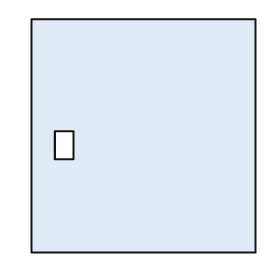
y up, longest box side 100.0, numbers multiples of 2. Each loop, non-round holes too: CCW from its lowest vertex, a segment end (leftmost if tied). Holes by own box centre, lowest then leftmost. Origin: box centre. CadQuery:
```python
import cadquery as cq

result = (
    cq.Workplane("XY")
    .moveTo(-48.0, -50.0)
    .lineTo(48.0, -50.0)
    .lineTo(48.0, 50.0)
    .lineTo(-48.0, 50.0)
    .close()
    .moveTo(-38.0, -10.0)
    .lineTo(-30.0, -10.0)
    .lineTo(-30.0, 2.0)
    .lineTo(-38.0, 2.0)
    .close()
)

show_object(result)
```